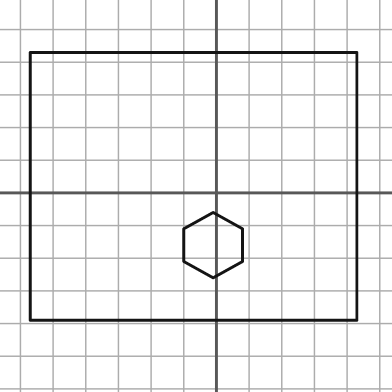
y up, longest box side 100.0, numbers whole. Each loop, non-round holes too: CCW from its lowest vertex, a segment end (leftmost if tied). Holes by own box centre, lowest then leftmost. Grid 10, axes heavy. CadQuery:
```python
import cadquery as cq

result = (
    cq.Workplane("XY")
    .moveTo(-57.0, -39.0)
    .lineTo(43.0, -39.0)
    .lineTo(43.0, 43.0)
    .lineTo(-57.0, 43.0)
    .close()
    .moveTo(-1.0, -26.0)
    .lineTo(8.0, -21.0)
    .lineTo(8.0, -11.0)
    .lineTo(-1.0, -6.0)
    .lineTo(-10.0, -11.0)
    .lineTo(-10.0, -21.0)
    .close()
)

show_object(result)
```